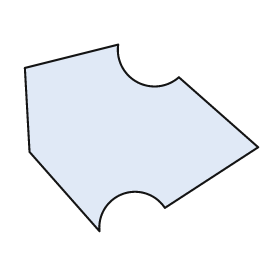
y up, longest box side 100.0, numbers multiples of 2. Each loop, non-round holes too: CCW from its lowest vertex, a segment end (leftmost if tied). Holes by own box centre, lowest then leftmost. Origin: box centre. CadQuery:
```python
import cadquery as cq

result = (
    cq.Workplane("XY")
    .moveTo(-18.0, -40.0)
    .threePointArc((-8.0, -24.0), (10.0, -30.0))
    .lineTo(50.0, -4.0)
    .lineTo(16.0, 26.0)
    .threePointArc((-2.0, 24.0), (-10.0, 40.0))
    .lineTo(-50.0, 30.0)
    .lineTo(-48.0, -6.0)
    .close()
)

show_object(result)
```